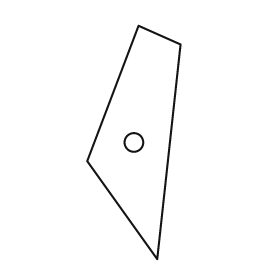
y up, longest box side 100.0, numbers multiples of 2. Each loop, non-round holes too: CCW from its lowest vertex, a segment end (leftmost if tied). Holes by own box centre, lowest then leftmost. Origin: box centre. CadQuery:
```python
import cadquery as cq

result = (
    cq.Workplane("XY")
    .moveTo(10.0, -50.0)
    .lineTo(20.0, 42.0)
    .lineTo(2.0, 50.0)
    .lineTo(-20.0, -8.0)
    .close()
    .moveTo(0.0, 0.0)
    .circle(4.0)
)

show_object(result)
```